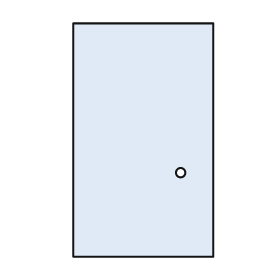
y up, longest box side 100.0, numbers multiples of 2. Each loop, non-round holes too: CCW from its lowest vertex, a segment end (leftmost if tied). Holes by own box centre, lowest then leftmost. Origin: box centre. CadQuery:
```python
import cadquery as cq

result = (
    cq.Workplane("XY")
    .moveTo(-30.0, -50.0)
    .lineTo(30.0, -50.0)
    .lineTo(30.0, 50.0)
    .lineTo(-30.0, 50.0)
    .close()
    .moveTo(16.0, -14.0)
    .circle(2.0)
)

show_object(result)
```